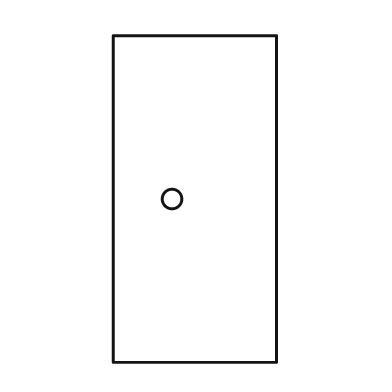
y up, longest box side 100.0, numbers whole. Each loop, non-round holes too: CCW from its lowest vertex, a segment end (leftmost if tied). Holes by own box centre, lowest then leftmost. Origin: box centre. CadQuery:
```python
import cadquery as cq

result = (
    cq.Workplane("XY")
    .moveTo(-25.0, -50.0)
    .lineTo(25.0, -50.0)
    .lineTo(25.0, 50.0)
    .lineTo(-25.0, 50.0)
    .close()
    .moveTo(-7.0, 0.0)
    .circle(3.0)
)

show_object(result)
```